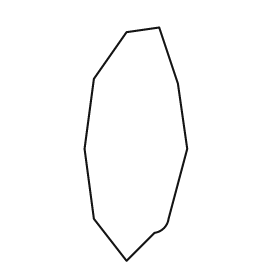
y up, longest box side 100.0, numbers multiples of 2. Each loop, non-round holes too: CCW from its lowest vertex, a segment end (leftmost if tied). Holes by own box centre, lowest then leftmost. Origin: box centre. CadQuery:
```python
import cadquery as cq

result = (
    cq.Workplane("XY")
    .moveTo(-4.0, -50.0)
    .lineTo(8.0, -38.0)
    .threePointArc((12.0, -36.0), (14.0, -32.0))
    .lineTo(22.0, -2.0)
    .lineTo(18.0, 26.0)
    .lineTo(10.0, 50.0)
    .lineTo(-4.0, 48.0)
    .lineTo(-18.0, 28.0)
    .lineTo(-22.0, -2.0)
    .lineTo(-18.0, -32.0)
    .close()
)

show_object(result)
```